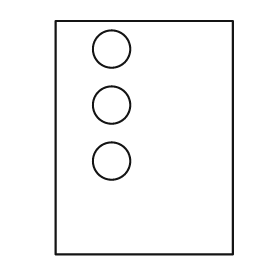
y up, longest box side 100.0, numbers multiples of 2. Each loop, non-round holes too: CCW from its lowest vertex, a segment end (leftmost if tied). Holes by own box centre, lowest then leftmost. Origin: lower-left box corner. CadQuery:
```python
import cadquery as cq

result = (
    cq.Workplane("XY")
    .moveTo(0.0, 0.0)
    .lineTo(76.0, 0.0)
    .lineTo(76.0, 100.0)
    .lineTo(0.0, 100.0)
    .close()
    .moveTo(24.0, 40.0)
    .circle(8.0)
    .moveTo(24.0, 64.0)
    .circle(8.0)
    .moveTo(24.0, 88.0)
    .circle(8.0)
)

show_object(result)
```